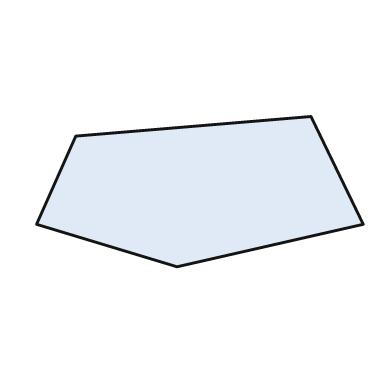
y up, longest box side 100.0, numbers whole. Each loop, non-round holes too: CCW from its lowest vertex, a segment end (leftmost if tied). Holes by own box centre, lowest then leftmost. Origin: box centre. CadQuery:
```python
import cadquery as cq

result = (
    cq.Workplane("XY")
    .moveTo(-7.0, -23.0)
    .lineTo(50.0, -10.0)
    .lineTo(34.0, 23.0)
    .lineTo(-38.0, 17.0)
    .lineTo(-50.0, -10.0)
    .close()
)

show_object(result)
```